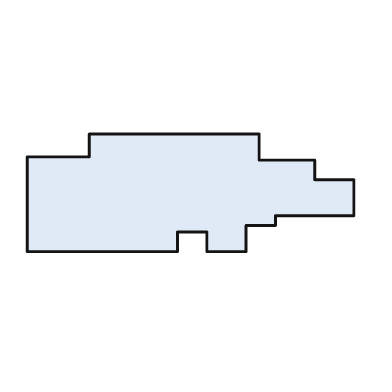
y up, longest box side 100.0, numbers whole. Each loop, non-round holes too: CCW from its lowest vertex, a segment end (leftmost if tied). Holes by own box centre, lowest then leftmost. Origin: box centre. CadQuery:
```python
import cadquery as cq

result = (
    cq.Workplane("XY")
    .moveTo(-50.0, -18.0)
    .lineTo(-4.0, -18.0)
    .lineTo(-4.0, -12.0)
    .lineTo(5.0, -12.0)
    .lineTo(5.0, -18.0)
    .lineTo(17.0, -18.0)
    .lineTo(17.0, -10.0)
    .lineTo(26.0, -10.0)
    .lineTo(26.0, -7.0)
    .lineTo(50.0, -7.0)
    .lineTo(50.0, 4.0)
    .lineTo(38.0, 4.0)
    .lineTo(38.0, 10.0)
    .lineTo(21.0, 10.0)
    .lineTo(21.0, 18.0)
    .lineTo(-31.0, 18.0)
    .lineTo(-31.0, 11.0)
    .lineTo(-50.0, 11.0)
    .close()
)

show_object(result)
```